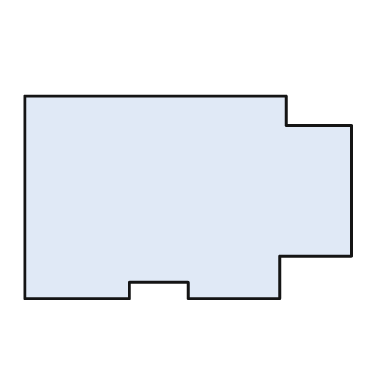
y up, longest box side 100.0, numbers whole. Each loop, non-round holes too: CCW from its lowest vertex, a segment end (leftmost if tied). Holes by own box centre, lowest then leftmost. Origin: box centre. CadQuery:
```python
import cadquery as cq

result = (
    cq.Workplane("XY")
    .moveTo(-50.0, -31.0)
    .lineTo(-18.0, -31.0)
    .lineTo(-18.0, -26.0)
    .lineTo(0.0, -26.0)
    .lineTo(0.0, -31.0)
    .lineTo(28.0, -31.0)
    .lineTo(28.0, -18.0)
    .lineTo(50.0, -18.0)
    .lineTo(50.0, 22.0)
    .lineTo(30.0, 22.0)
    .lineTo(30.0, 31.0)
    .lineTo(-50.0, 31.0)
    .close()
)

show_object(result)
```